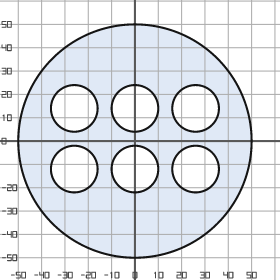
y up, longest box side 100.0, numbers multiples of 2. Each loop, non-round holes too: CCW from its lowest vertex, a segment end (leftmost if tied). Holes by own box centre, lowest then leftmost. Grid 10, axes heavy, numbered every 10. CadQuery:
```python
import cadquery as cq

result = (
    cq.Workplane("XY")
    .moveTo(0.0, 0.0)
    .circle(50.0)
    .moveTo(-26.0, -12.0)
    .circle(10.0)
    .moveTo(0.0, -12.0)
    .circle(10.0)
    .moveTo(26.0, -12.0)
    .circle(10.0)
    .moveTo(-26.0, 14.0)
    .circle(10.0)
    .moveTo(0.0, 14.0)
    .circle(10.0)
    .moveTo(26.0, 14.0)
    .circle(10.0)
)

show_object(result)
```